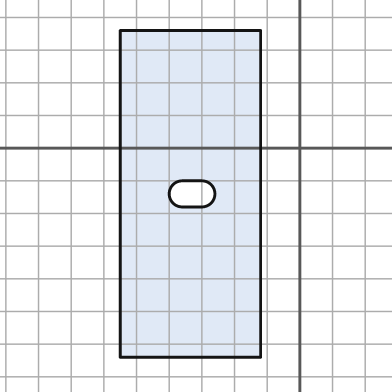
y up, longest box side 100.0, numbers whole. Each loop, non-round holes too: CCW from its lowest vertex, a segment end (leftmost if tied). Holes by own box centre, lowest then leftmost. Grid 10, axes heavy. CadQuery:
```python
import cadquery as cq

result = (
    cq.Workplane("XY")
    .moveTo(-55.0, -64.0)
    .lineTo(-12.0, -64.0)
    .lineTo(-12.0, 36.0)
    .lineTo(-55.0, 36.0)
    .close()
    .moveTo(-36.0, -18.0)
    .lineTo(-30.0, -18.0)
    .threePointArc((-26.0, -14.0), (-30.0, -10.0))
    .lineTo(-36.0, -10.0)
    .threePointArc((-40.0, -14.0), (-36.0, -18.0))
    .close()
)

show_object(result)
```